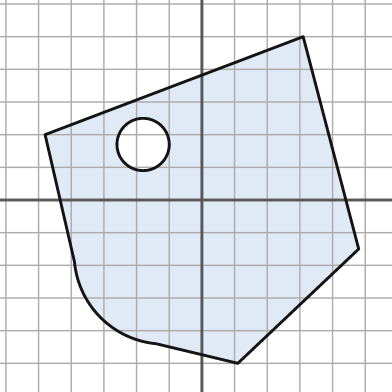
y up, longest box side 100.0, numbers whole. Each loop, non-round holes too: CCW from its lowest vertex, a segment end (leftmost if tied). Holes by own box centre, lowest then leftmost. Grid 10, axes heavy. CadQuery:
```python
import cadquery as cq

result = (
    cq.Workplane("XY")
    .moveTo(11.0, -50.0)
    .lineTo(48.0, -15.0)
    .lineTo(31.0, 50.0)
    .lineTo(-48.0, 20.0)
    .lineTo(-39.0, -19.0)
    .threePointArc((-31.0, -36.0), (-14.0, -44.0))
    .close()
    .moveTo(-18.0, 17.0)
    .circle(8.0)
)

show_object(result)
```